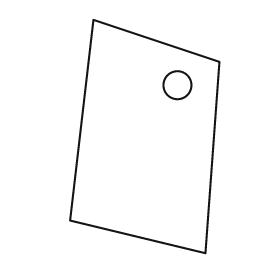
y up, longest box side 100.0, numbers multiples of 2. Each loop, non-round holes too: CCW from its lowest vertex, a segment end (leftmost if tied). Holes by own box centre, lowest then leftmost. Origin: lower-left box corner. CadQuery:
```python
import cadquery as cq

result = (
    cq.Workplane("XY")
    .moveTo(58.0, 0.0)
    .lineTo(64.0, 82.0)
    .lineTo(10.0, 100.0)
    .lineTo(0.0, 14.0)
    .close()
    .moveTo(46.0, 72.0)
    .circle(6.0)
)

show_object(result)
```